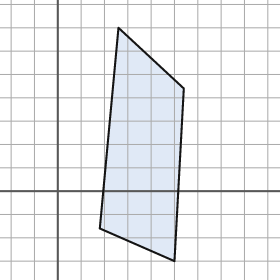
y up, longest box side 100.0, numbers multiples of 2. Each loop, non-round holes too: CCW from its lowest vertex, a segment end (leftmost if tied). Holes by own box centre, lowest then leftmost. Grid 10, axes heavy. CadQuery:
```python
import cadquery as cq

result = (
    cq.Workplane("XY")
    .moveTo(50.0, -30.0)
    .lineTo(54.0, 44.0)
    .lineTo(26.0, 70.0)
    .lineTo(18.0, -16.0)
    .close()
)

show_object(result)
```